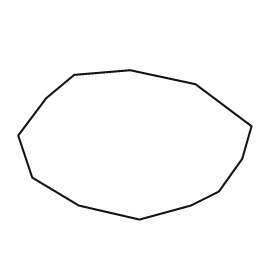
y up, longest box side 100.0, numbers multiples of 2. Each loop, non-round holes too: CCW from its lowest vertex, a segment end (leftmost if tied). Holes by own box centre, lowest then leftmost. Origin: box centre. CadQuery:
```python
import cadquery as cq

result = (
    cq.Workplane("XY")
    .moveTo(2.0, -32.0)
    .lineTo(24.0, -26.0)
    .lineTo(36.0, -20.0)
    .lineTo(46.0, -6.0)
    .lineTo(50.0, 8.0)
    .lineTo(26.0, 26.0)
    .lineTo(-2.0, 32.0)
    .lineTo(-26.0, 30.0)
    .lineTo(-38.0, 20.0)
    .lineTo(-50.0, 4.0)
    .lineTo(-44.0, -14.0)
    .lineTo(-24.0, -26.0)
    .close()
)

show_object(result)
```